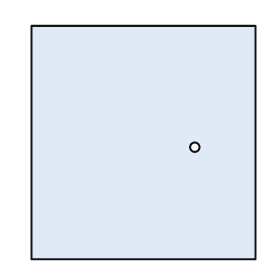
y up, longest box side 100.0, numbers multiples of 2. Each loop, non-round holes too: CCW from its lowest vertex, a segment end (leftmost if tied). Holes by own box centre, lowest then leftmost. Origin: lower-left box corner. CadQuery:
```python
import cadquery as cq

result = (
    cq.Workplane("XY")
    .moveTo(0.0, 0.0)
    .lineTo(96.0, 0.0)
    .lineTo(96.0, 100.0)
    .lineTo(0.0, 100.0)
    .close()
    .moveTo(70.0, 48.0)
    .circle(2.0)
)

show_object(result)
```